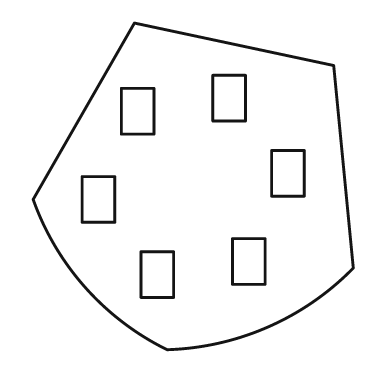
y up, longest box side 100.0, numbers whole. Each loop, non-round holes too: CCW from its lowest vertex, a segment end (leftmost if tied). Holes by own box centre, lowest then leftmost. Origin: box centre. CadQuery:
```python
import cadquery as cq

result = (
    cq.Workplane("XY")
    .moveTo(-8.0, -50.0)
    .threePointArc((23.0, -43.0), (49.0, -25.0))
    .lineTo(43.0, 37.0)
    .lineTo(-18.0, 50.0)
    .lineTo(-49.0, -4.0)
    .threePointArc((-33.0, -31.0), (-8.0, -50.0))
    .close()
    .moveTo(-16.0, -34.0)
    .lineTo(-6.0, -34.0)
    .lineTo(-6.0, -20.0)
    .lineTo(-16.0, -20.0)
    .close()
    .moveTo(12.0, -30.0)
    .lineTo(22.0, -30.0)
    .lineTo(22.0, -16.0)
    .lineTo(12.0, -16.0)
    .close()
    .moveTo(-34.0, -11.0)
    .lineTo(-24.0, -11.0)
    .lineTo(-24.0, 3.0)
    .lineTo(-34.0, 3.0)
    .close()
    .moveTo(24.0, -3.0)
    .lineTo(34.0, -3.0)
    .lineTo(34.0, 11.0)
    .lineTo(24.0, 11.0)
    .close()
    .moveTo(-22.0, 16.0)
    .lineTo(-12.0, 16.0)
    .lineTo(-12.0, 30.0)
    .lineTo(-22.0, 30.0)
    .close()
    .moveTo(6.0, 20.0)
    .lineTo(16.0, 20.0)
    .lineTo(16.0, 34.0)
    .lineTo(6.0, 34.0)
    .close()
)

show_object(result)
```